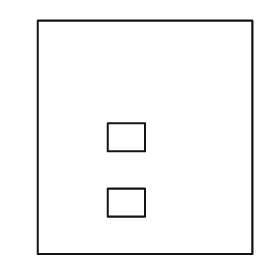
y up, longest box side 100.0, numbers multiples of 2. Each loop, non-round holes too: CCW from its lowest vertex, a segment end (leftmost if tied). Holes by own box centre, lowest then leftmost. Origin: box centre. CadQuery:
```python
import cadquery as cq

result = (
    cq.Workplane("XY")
    .moveTo(-46.0, -50.0)
    .lineTo(46.0, -50.0)
    .lineTo(46.0, 50.0)
    .lineTo(-46.0, 50.0)
    .close()
    .moveTo(-16.0, -34.0)
    .lineTo(0.0, -34.0)
    .lineTo(0.0, -22.0)
    .lineTo(-16.0, -22.0)
    .close()
    .moveTo(-16.0, -6.0)
    .lineTo(0.0, -6.0)
    .lineTo(0.0, 6.0)
    .lineTo(-16.0, 6.0)
    .close()
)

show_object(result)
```